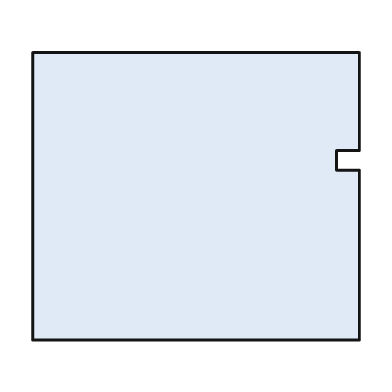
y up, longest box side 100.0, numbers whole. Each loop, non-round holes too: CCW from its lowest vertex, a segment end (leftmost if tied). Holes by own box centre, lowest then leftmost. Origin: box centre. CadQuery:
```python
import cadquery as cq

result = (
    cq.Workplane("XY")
    .moveTo(-50.0, -44.0)
    .lineTo(50.0, -44.0)
    .lineTo(50.0, 8.0)
    .lineTo(43.0, 8.0)
    .lineTo(43.0, 14.0)
    .lineTo(50.0, 14.0)
    .lineTo(50.0, 44.0)
    .lineTo(-50.0, 44.0)
    .close()
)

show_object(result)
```